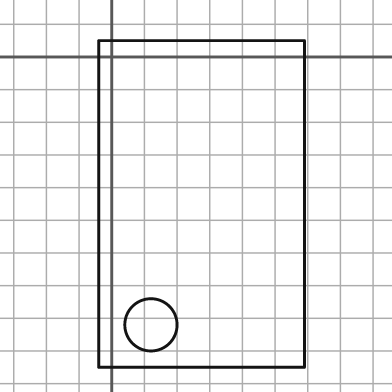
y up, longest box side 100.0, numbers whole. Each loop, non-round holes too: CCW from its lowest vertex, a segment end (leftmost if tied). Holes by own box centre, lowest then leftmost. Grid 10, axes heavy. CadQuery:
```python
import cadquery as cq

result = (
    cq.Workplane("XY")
    .moveTo(-4.0, -95.0)
    .lineTo(59.0, -95.0)
    .lineTo(59.0, 5.0)
    .lineTo(-4.0, 5.0)
    .close()
    .moveTo(12.0, -82.0)
    .circle(8.0)
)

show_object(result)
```